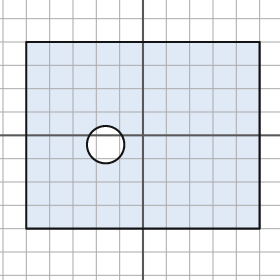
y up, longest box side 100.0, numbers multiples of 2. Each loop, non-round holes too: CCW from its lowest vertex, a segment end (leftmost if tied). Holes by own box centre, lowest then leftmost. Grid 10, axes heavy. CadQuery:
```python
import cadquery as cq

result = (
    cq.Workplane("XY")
    .moveTo(-50.0, -40.0)
    .lineTo(50.0, -40.0)
    .lineTo(50.0, 40.0)
    .lineTo(-50.0, 40.0)
    .close()
    .moveTo(-16.0, -4.0)
    .circle(8.0)
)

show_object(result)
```